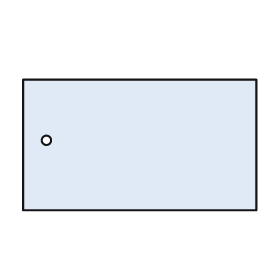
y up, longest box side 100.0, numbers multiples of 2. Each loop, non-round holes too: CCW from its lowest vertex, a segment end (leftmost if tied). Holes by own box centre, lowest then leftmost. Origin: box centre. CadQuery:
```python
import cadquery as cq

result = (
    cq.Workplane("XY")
    .moveTo(-50.0, -28.0)
    .lineTo(50.0, -28.0)
    .lineTo(50.0, 28.0)
    .lineTo(-50.0, 28.0)
    .close()
    .moveTo(-40.0, 2.0)
    .circle(2.0)
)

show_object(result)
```